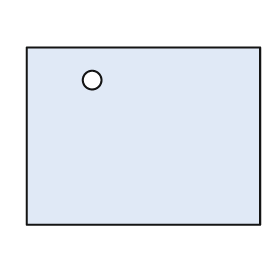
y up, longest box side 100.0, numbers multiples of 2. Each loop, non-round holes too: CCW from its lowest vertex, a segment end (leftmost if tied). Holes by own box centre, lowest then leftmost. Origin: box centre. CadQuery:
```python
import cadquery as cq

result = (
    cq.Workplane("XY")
    .moveTo(-50.0, -38.0)
    .lineTo(50.0, -38.0)
    .lineTo(50.0, 38.0)
    .lineTo(-50.0, 38.0)
    .close()
    .moveTo(-22.0, 24.0)
    .circle(4.0)
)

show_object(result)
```